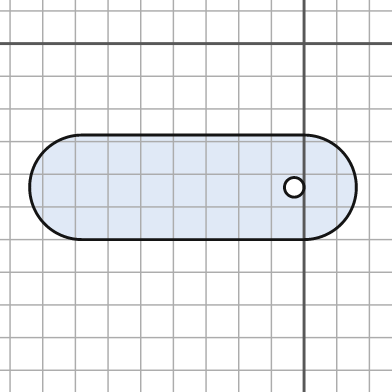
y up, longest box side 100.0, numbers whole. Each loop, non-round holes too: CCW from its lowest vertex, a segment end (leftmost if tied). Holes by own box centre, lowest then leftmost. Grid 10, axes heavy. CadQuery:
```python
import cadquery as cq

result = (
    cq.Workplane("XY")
    .moveTo(-68.0, -60.0)
    .lineTo(0.0, -60.0)
    .threePointArc((16.0, -44.0), (0.0, -28.0))
    .lineTo(-68.0, -28.0)
    .threePointArc((-84.0, -44.0), (-68.0, -60.0))
    .close()
    .moveTo(-3.0, -44.0)
    .circle(3.0)
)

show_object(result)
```